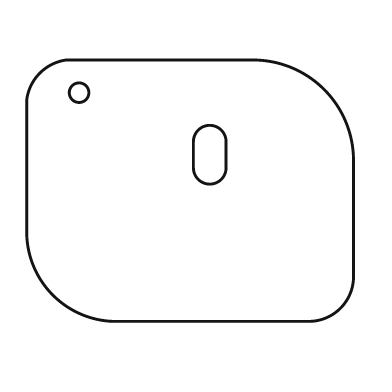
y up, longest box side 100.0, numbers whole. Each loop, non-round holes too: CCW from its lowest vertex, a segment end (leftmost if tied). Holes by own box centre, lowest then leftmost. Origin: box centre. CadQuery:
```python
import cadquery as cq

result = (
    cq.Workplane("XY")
    .moveTo(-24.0, -40.0)
    .lineTo(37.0, -40.0)
    .threePointArc((46.0, -36.0), (50.0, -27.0))
    .lineTo(50.0, 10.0)
    .threePointArc((41.0, 31.0), (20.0, 40.0))
    .lineTo(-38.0, 40.0)
    .threePointArc((-46.0, 36.0), (-50.0, 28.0))
    .lineTo(-50.0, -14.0)
    .threePointArc((-42.0, -32.0), (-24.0, -40.0))
    .close()
    .moveTo(1.0, 7.0)
    .threePointArc((6.0, 2.0), (11.0, 7.0))
    .lineTo(11.0, 15.0)
    .threePointArc((6.0, 20.0), (1.0, 15.0))
    .close()
    .moveTo(-34.0, 30.0)
    .circle(3.0)
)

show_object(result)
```